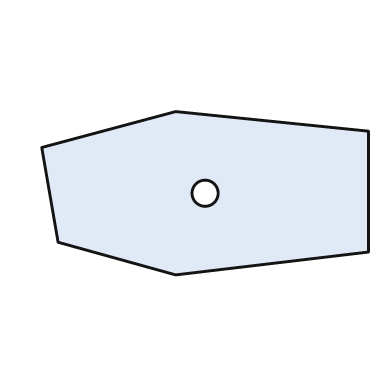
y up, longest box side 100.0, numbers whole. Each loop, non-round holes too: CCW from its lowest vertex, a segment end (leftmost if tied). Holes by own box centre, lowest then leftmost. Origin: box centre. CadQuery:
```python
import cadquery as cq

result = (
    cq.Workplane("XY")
    .moveTo(-9.0, -25.0)
    .lineTo(50.0, -18.0)
    .lineTo(50.0, 19.0)
    .lineTo(-9.0, 25.0)
    .lineTo(-50.0, 14.0)
    .lineTo(-45.0, -15.0)
    .close()
    .moveTo(0.0, 0.0)
    .circle(4.0)
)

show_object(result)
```